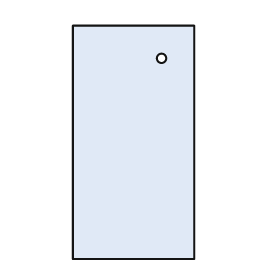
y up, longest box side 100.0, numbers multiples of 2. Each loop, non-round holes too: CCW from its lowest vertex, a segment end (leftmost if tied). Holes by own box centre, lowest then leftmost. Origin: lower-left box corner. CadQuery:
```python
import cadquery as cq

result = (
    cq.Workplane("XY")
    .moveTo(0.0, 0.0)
    .lineTo(52.0, 0.0)
    .lineTo(52.0, 100.0)
    .lineTo(0.0, 100.0)
    .close()
    .moveTo(38.0, 86.0)
    .circle(2.0)
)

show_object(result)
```